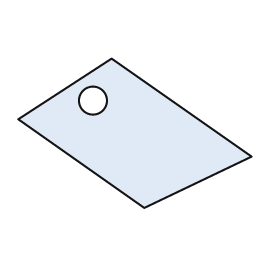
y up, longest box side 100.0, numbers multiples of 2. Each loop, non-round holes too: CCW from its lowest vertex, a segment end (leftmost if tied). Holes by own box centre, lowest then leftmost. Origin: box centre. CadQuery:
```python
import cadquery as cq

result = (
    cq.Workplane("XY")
    .moveTo(4.0, -32.0)
    .lineTo(50.0, -10.0)
    .lineTo(-10.0, 32.0)
    .lineTo(-50.0, 6.0)
    .close()
    .moveTo(-18.0, 14.0)
    .circle(6.0)
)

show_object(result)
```